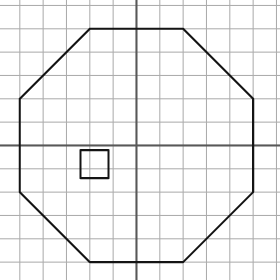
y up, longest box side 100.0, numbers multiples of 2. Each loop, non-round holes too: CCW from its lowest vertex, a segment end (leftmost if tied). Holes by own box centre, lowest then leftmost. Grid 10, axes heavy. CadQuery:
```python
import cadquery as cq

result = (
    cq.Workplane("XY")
    .moveTo(-20.0, -50.0)
    .lineTo(20.0, -50.0)
    .lineTo(50.0, -20.0)
    .lineTo(50.0, 20.0)
    .lineTo(20.0, 50.0)
    .lineTo(-20.0, 50.0)
    .lineTo(-50.0, 20.0)
    .lineTo(-50.0, -20.0)
    .close()
    .moveTo(-24.0, -14.0)
    .lineTo(-12.0, -14.0)
    .lineTo(-12.0, -2.0)
    .lineTo(-24.0, -2.0)
    .close()
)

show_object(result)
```